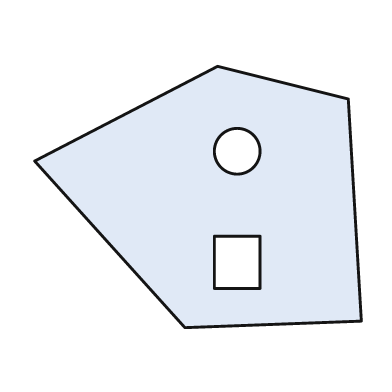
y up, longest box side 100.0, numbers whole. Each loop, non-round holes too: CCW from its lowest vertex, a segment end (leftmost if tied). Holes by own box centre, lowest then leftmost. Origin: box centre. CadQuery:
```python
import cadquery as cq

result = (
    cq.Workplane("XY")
    .moveTo(-4.0, -40.0)
    .lineTo(50.0, -38.0)
    .lineTo(46.0, 30.0)
    .lineTo(6.0, 40.0)
    .lineTo(-50.0, 11.0)
    .close()
    .moveTo(5.0, -28.0)
    .lineTo(19.0, -28.0)
    .lineTo(19.0, -12.0)
    .lineTo(5.0, -12.0)
    .close()
    .moveTo(12.0, 14.0)
    .circle(7.0)
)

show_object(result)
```